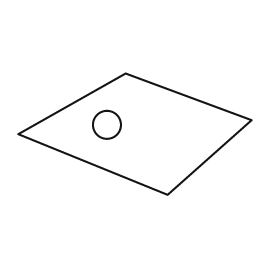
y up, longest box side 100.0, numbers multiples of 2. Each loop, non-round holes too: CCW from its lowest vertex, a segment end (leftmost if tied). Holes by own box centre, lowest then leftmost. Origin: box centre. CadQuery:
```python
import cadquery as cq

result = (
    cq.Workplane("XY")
    .moveTo(14.0, -26.0)
    .lineTo(50.0, 6.0)
    .lineTo(-4.0, 26.0)
    .lineTo(-50.0, 0.0)
    .close()
    .moveTo(-12.0, 4.0)
    .circle(6.0)
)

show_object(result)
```